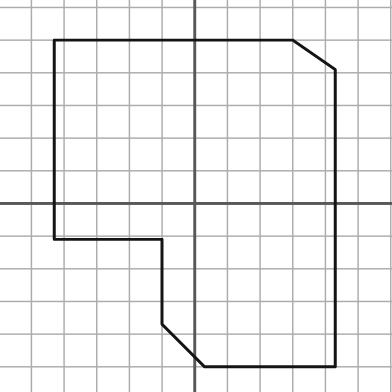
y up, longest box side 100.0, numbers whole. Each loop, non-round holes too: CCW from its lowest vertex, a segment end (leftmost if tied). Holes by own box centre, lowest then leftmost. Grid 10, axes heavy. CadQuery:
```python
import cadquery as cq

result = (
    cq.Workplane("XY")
    .moveTo(3.0, -50.0)
    .lineTo(43.0, -50.0)
    .lineTo(43.0, 41.0)
    .lineTo(30.0, 50.0)
    .lineTo(-43.0, 50.0)
    .lineTo(-43.0, -11.0)
    .lineTo(-10.0, -11.0)
    .lineTo(-10.0, -37.0)
    .close()
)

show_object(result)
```